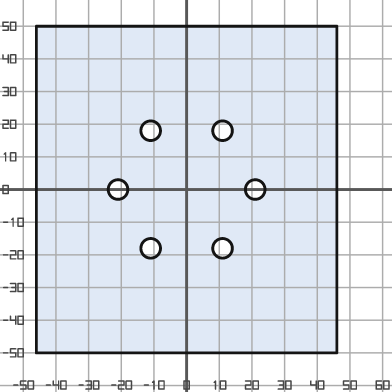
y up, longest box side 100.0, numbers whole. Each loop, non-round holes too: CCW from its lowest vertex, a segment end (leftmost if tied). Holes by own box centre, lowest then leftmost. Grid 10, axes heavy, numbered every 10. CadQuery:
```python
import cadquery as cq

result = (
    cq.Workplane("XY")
    .moveTo(-46.0, -50.0)
    .lineTo(46.0, -50.0)
    .lineTo(46.0, 50.0)
    .lineTo(-46.0, 50.0)
    .close()
    .moveTo(-11.0, -18.0)
    .circle(3.0)
    .moveTo(11.0, -18.0)
    .circle(3.0)
    .moveTo(-21.0, 0.0)
    .circle(3.0)
    .moveTo(21.0, 0.0)
    .circle(3.0)
    .moveTo(-11.0, 18.0)
    .circle(3.0)
    .moveTo(11.0, 18.0)
    .circle(3.0)
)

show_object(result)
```